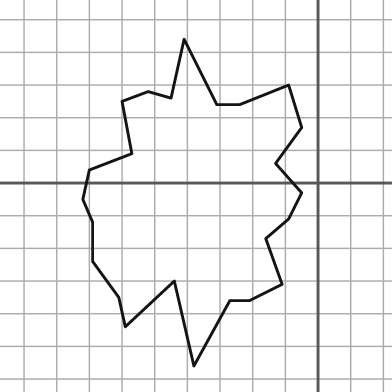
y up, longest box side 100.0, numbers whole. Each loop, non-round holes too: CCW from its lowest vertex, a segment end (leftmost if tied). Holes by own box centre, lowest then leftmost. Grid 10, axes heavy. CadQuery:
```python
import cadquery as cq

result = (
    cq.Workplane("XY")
    .moveTo(-38.0, -56.0)
    .lineTo(-27.0, -36.0)
    .lineTo(-21.0, -36.0)
    .lineTo(-11.0, -31.0)
    .lineTo(-16.0, -17.0)
    .lineTo(-9.0, -11.0)
    .lineTo(-5.0, -3.0)
    .lineTo(-13.0, 6.0)
    .lineTo(-5.0, 17.0)
    .lineTo(-9.0, 30.0)
    .lineTo(-24.0, 24.0)
    .lineTo(-31.0, 24.0)
    .lineTo(-41.0, 44.0)
    .lineTo(-45.0, 26.0)
    .lineTo(-52.0, 28.0)
    .lineTo(-60.0, 25.0)
    .lineTo(-57.0, 9.0)
    .lineTo(-70.0, 4.0)
    .lineTo(-72.0, -5.0)
    .lineTo(-69.0, -12.0)
    .lineTo(-69.0, -24.0)
    .lineTo(-61.0, -35.0)
    .lineTo(-59.0, -44.0)
    .lineTo(-44.0, -30.0)
    .close()
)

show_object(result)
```